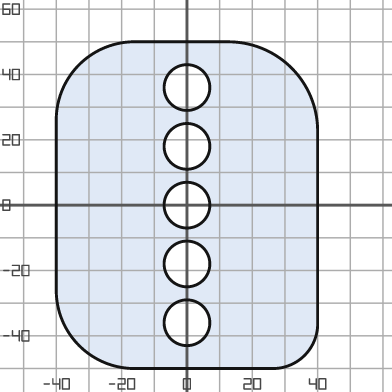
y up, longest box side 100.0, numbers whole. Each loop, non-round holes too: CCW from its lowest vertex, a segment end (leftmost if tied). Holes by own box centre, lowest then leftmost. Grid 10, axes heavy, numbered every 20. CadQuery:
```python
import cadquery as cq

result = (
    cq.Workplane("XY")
    .moveTo(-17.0, -50.0)
    .lineTo(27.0, -50.0)
    .threePointArc((36.0, -46.0), (40.0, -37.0))
    .lineTo(40.0, 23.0)
    .threePointArc((32.0, 42.0), (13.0, 50.0))
    .lineTo(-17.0, 50.0)
    .threePointArc((-33.0, 43.0), (-40.0, 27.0))
    .lineTo(-40.0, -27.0)
    .threePointArc((-33.0, -43.0), (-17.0, -50.0))
    .close()
    .moveTo(0.0, -36.0)
    .circle(7.0)
    .moveTo(0.0, -18.0)
    .circle(7.0)
    .moveTo(0.0, 0.0)
    .circle(7.0)
    .moveTo(0.0, 18.0)
    .circle(7.0)
    .moveTo(0.0, 36.0)
    .circle(7.0)
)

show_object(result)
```